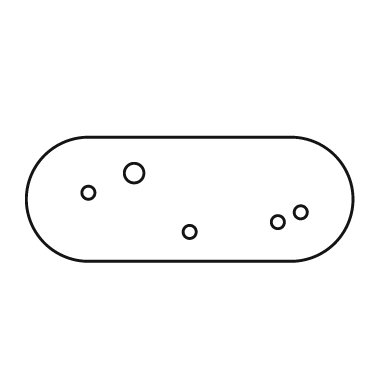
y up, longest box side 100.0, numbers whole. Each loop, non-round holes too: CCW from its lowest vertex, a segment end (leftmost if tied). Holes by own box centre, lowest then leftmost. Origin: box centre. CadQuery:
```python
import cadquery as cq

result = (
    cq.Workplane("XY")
    .moveTo(-31.0, -19.0)
    .lineTo(31.0, -19.0)
    .threePointArc((50.0, 0.0), (31.0, 19.0))
    .lineTo(-31.0, 19.0)
    .threePointArc((-50.0, 0.0), (-31.0, -19.0))
    .close()
    .moveTo(0.0, -10.0)
    .circle(2.0)
    .moveTo(27.0, -7.0)
    .circle(2.0)
    .moveTo(34.0, -4.0)
    .circle(2.0)
    .moveTo(-31.0, 2.0)
    .circle(2.0)
    .moveTo(-17.0, 8.0)
    .circle(3.0)
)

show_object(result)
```